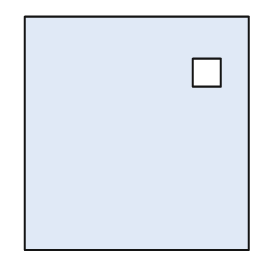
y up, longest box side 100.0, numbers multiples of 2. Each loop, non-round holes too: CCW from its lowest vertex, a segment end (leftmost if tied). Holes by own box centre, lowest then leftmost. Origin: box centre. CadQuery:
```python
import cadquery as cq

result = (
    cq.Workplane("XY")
    .moveTo(-48.0, -50.0)
    .lineTo(48.0, -50.0)
    .lineTo(48.0, 50.0)
    .lineTo(-48.0, 50.0)
    .close()
    .moveTo(24.0, 20.0)
    .lineTo(36.0, 20.0)
    .lineTo(36.0, 32.0)
    .lineTo(24.0, 32.0)
    .close()
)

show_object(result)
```